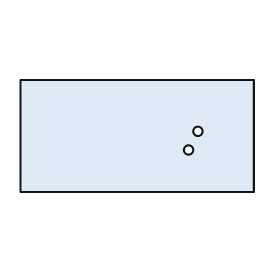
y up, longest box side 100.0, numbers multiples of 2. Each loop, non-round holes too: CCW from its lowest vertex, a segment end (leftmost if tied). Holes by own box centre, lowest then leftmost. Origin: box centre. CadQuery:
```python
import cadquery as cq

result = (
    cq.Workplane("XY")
    .moveTo(-50.0, -24.0)
    .lineTo(50.0, -24.0)
    .lineTo(50.0, 24.0)
    .lineTo(-50.0, 24.0)
    .close()
    .moveTo(22.0, -6.0)
    .circle(2.0)
    .moveTo(26.0, 2.0)
    .circle(2.0)
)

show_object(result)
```